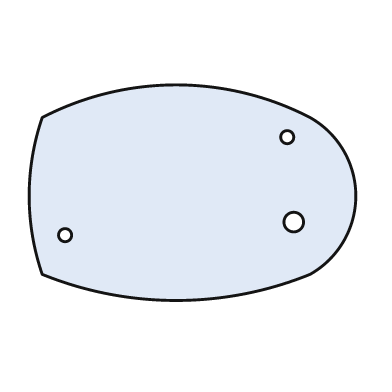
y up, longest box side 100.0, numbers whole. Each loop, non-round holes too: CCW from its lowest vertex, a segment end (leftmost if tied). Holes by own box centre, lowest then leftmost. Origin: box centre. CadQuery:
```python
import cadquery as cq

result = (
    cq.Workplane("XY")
    .moveTo(-46.0, -25.0)
    .threePointArc((-5.0, -33.0), (36.0, -25.0))
    .threePointArc((50.0, -1.0), (36.0, 23.0))
    .threePointArc((-5.0, 33.0), (-46.0, 23.0))
    .threePointArc((-50.0, -1.0), (-46.0, -25.0))
    .close()
    .moveTo(-39.0, -13.0)
    .circle(2.0)
    .moveTo(31.0, -9.0)
    .circle(3.0)
    .moveTo(29.0, 17.0)
    .circle(2.0)
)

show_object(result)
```